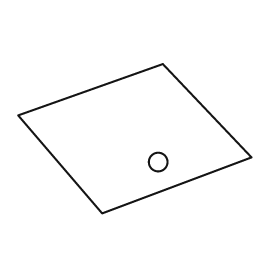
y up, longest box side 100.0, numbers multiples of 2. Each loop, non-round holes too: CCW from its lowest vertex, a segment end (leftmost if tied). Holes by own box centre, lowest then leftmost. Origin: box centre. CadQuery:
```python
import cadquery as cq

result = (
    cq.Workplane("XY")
    .moveTo(-14.0, -32.0)
    .lineTo(50.0, -8.0)
    .lineTo(12.0, 32.0)
    .lineTo(-50.0, 10.0)
    .close()
    .moveTo(10.0, -10.0)
    .circle(4.0)
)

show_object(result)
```